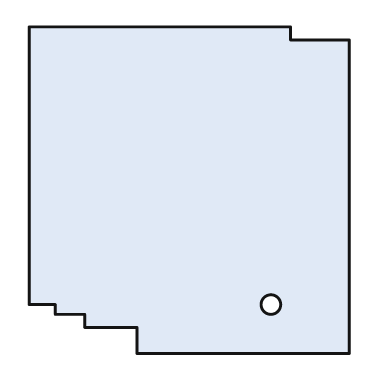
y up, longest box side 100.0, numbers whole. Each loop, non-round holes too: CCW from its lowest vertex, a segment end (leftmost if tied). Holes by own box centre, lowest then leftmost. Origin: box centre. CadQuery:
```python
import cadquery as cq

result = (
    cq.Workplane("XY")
    .moveTo(-16.0, -50.0)
    .lineTo(49.0, -50.0)
    .lineTo(49.0, 46.0)
    .lineTo(31.0, 46.0)
    .lineTo(31.0, 50.0)
    .lineTo(-49.0, 50.0)
    .lineTo(-49.0, -35.0)
    .lineTo(-41.0, -35.0)
    .lineTo(-41.0, -38.0)
    .lineTo(-32.0, -38.0)
    .lineTo(-32.0, -42.0)
    .lineTo(-16.0, -42.0)
    .close()
    .moveTo(25.0, -35.0)
    .circle(3.0)
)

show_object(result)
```